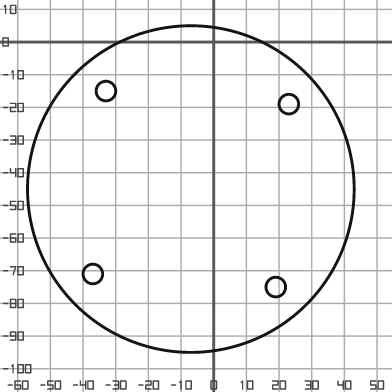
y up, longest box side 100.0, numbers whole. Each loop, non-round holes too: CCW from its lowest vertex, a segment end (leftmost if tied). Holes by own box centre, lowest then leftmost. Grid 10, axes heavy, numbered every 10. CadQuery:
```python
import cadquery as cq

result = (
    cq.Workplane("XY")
    .moveTo(-7.0, -45.0)
    .circle(50.0)
    .moveTo(19.0, -75.0)
    .circle(3.0)
    .moveTo(-37.0, -71.0)
    .circle(3.0)
    .moveTo(23.0, -19.0)
    .circle(3.0)
    .moveTo(-33.0, -15.0)
    .circle(3.0)
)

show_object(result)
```